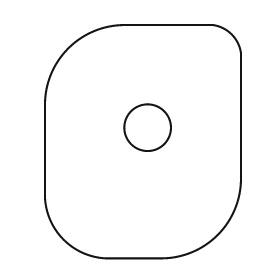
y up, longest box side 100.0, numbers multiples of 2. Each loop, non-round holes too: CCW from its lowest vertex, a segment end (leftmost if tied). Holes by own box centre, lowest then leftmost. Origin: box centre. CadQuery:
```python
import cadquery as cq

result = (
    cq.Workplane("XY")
    .moveTo(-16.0, -50.0)
    .lineTo(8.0, -50.0)
    .threePointArc((32.0, -40.0), (42.0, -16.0))
    .lineTo(42.0, 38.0)
    .threePointArc((38.0, 46.0), (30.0, 50.0))
    .lineTo(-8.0, 50.0)
    .threePointArc((-32.0, 40.0), (-42.0, 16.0))
    .lineTo(-42.0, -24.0)
    .threePointArc((-34.0, -42.0), (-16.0, -50.0))
    .close()
    .moveTo(2.0, 6.0)
    .circle(10.0)
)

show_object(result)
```